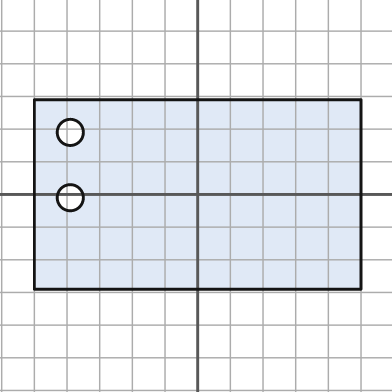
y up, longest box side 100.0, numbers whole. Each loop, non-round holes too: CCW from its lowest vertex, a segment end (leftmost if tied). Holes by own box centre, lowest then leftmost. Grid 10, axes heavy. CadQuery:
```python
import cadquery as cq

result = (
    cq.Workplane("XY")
    .moveTo(-50.0, -29.0)
    .lineTo(50.0, -29.0)
    .lineTo(50.0, 29.0)
    .lineTo(-50.0, 29.0)
    .close()
    .moveTo(-39.0, -1.0)
    .circle(4.0)
    .moveTo(-39.0, 19.0)
    .circle(4.0)
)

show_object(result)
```